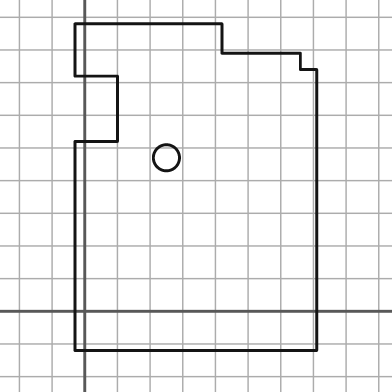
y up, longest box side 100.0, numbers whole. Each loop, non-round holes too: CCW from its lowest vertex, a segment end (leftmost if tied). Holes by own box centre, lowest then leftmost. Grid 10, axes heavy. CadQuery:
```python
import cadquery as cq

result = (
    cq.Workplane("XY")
    .moveTo(-3.0, -12.0)
    .lineTo(71.0, -12.0)
    .lineTo(71.0, 74.0)
    .lineTo(66.0, 74.0)
    .lineTo(66.0, 79.0)
    .lineTo(42.0, 79.0)
    .lineTo(42.0, 88.0)
    .lineTo(-3.0, 88.0)
    .lineTo(-3.0, 72.0)
    .lineTo(10.0, 72.0)
    .lineTo(10.0, 52.0)
    .lineTo(-3.0, 52.0)
    .close()
    .moveTo(25.0, 47.0)
    .circle(4.0)
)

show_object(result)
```